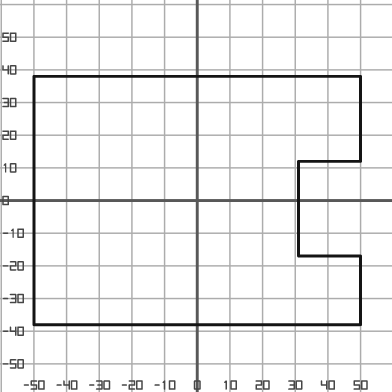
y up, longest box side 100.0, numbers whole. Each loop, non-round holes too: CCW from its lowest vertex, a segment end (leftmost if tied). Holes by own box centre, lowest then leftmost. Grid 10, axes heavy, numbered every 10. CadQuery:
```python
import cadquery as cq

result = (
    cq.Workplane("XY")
    .moveTo(-50.0, -38.0)
    .lineTo(50.0, -38.0)
    .lineTo(50.0, -17.0)
    .lineTo(31.0, -17.0)
    .lineTo(31.0, 12.0)
    .lineTo(50.0, 12.0)
    .lineTo(50.0, 38.0)
    .lineTo(-50.0, 38.0)
    .close()
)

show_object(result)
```